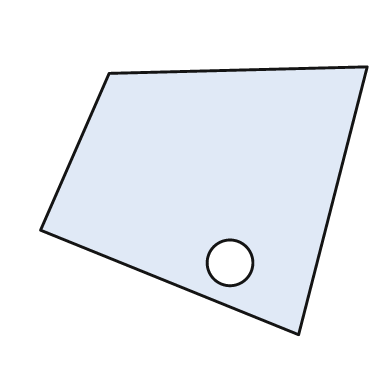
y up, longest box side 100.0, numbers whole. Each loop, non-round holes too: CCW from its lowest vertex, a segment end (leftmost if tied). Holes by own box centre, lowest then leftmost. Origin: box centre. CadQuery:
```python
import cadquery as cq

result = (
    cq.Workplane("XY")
    .moveTo(29.0, -41.0)
    .lineTo(50.0, 41.0)
    .lineTo(-29.0, 39.0)
    .lineTo(-50.0, -9.0)
    .close()
    .moveTo(8.0, -19.0)
    .circle(7.0)
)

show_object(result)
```